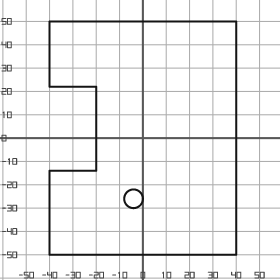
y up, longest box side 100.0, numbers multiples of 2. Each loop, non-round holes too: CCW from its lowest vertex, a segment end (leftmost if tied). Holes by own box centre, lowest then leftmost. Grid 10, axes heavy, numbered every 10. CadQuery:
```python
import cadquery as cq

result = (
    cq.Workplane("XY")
    .moveTo(-40.0, -50.0)
    .lineTo(40.0, -50.0)
    .lineTo(40.0, 50.0)
    .lineTo(-40.0, 50.0)
    .lineTo(-40.0, 22.0)
    .lineTo(-20.0, 22.0)
    .lineTo(-20.0, -14.0)
    .lineTo(-40.0, -14.0)
    .close()
    .moveTo(-4.0, -26.0)
    .circle(4.0)
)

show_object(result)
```